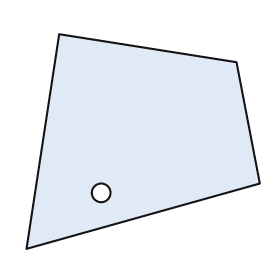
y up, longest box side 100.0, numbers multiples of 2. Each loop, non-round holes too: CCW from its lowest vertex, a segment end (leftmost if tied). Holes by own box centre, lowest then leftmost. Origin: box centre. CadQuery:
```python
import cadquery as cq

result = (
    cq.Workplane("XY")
    .moveTo(-50.0, -46.0)
    .lineTo(50.0, -18.0)
    .lineTo(40.0, 34.0)
    .lineTo(-36.0, 46.0)
    .close()
    .moveTo(-18.0, -22.0)
    .circle(4.0)
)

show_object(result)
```